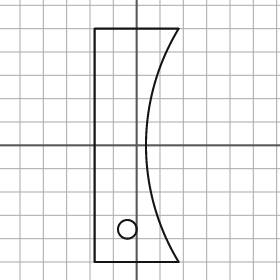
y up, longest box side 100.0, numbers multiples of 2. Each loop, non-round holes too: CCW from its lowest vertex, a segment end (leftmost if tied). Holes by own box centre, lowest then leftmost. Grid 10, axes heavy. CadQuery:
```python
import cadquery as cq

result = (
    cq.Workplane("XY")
    .moveTo(-18.0, -50.0)
    .lineTo(18.0, -50.0)
    .threePointArc((4.0, 0.0), (18.0, 50.0))
    .lineTo(-18.0, 50.0)
    .close()
    .moveTo(-4.0, -36.0)
    .circle(4.0)
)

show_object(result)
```